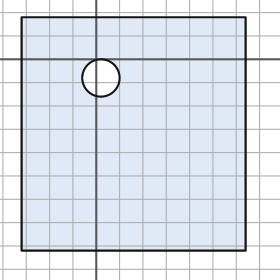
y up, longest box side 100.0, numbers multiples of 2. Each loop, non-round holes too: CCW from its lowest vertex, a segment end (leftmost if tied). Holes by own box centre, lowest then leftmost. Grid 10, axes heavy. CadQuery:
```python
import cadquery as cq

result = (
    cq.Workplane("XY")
    .moveTo(-32.0, -82.0)
    .lineTo(64.0, -82.0)
    .lineTo(64.0, 18.0)
    .lineTo(-32.0, 18.0)
    .close()
    .moveTo(2.0, -8.0)
    .circle(8.0)
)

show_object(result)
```